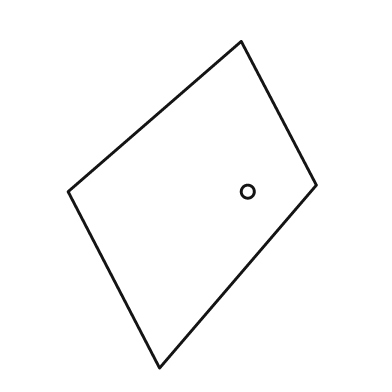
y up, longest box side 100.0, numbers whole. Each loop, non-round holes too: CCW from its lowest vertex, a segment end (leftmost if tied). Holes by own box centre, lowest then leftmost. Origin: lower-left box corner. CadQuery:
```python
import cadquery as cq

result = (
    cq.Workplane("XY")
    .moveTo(28.0, 0.0)
    .lineTo(76.0, 56.0)
    .lineTo(53.0, 100.0)
    .lineTo(0.0, 54.0)
    .close()
    .moveTo(55.0, 54.0)
    .circle(2.0)
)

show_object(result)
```